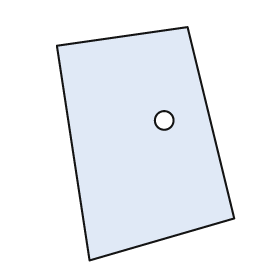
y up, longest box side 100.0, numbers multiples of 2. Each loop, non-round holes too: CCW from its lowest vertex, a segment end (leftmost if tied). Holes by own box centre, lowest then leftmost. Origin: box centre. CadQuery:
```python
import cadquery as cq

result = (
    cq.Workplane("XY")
    .moveTo(-24.0, -50.0)
    .lineTo(38.0, -32.0)
    .lineTo(18.0, 50.0)
    .lineTo(-38.0, 42.0)
    .close()
    .moveTo(8.0, 10.0)
    .circle(4.0)
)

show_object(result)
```